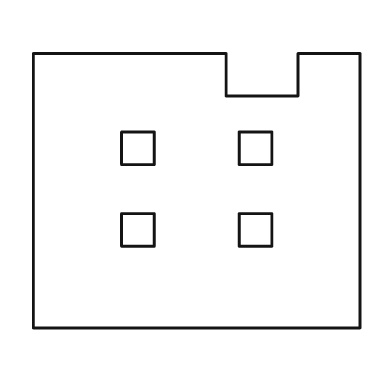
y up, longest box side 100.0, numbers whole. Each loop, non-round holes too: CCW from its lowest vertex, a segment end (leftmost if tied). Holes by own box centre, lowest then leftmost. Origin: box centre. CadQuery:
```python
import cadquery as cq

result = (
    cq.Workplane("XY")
    .moveTo(-50.0, -42.0)
    .lineTo(50.0, -42.0)
    .lineTo(50.0, 42.0)
    .lineTo(31.0, 42.0)
    .lineTo(31.0, 29.0)
    .lineTo(9.0, 29.0)
    .lineTo(9.0, 42.0)
    .lineTo(-50.0, 42.0)
    .close()
    .moveTo(-23.0, -17.0)
    .lineTo(-13.0, -17.0)
    .lineTo(-13.0, -7.0)
    .lineTo(-23.0, -7.0)
    .close()
    .moveTo(13.0, -17.0)
    .lineTo(23.0, -17.0)
    .lineTo(23.0, -7.0)
    .lineTo(13.0, -7.0)
    .close()
    .moveTo(-23.0, 8.0)
    .lineTo(-13.0, 8.0)
    .lineTo(-13.0, 18.0)
    .lineTo(-23.0, 18.0)
    .close()
    .moveTo(13.0, 8.0)
    .lineTo(23.0, 8.0)
    .lineTo(23.0, 18.0)
    .lineTo(13.0, 18.0)
    .close()
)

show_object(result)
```